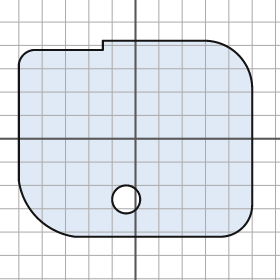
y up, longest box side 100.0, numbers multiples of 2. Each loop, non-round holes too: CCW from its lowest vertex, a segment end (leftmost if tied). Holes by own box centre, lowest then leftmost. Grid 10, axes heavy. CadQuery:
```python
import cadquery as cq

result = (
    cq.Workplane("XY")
    .moveTo(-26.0, -42.0)
    .lineTo(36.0, -42.0)
    .threePointArc((46.0, -38.0), (50.0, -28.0))
    .lineTo(50.0, 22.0)
    .threePointArc((44.0, 36.0), (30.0, 42.0))
    .lineTo(-14.0, 42.0)
    .lineTo(-14.0, 38.0)
    .lineTo(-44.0, 38.0)
    .threePointArc((-48.0, 36.0), (-50.0, 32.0))
    .lineTo(-50.0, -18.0)
    .threePointArc((-42.0, -34.0), (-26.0, -42.0))
    .close()
    .moveTo(-4.0, -26.0)
    .circle(6.0)
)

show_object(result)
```